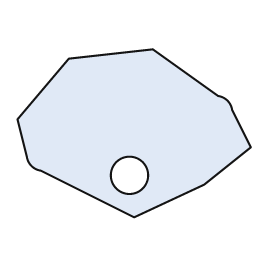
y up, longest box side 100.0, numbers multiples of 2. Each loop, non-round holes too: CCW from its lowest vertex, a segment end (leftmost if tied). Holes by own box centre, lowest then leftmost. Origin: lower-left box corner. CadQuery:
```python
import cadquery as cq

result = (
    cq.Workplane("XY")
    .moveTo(50.0, 0.0)
    .lineTo(80.0, 14.0)
    .lineTo(100.0, 30.0)
    .lineTo(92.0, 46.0)
    .threePointArc((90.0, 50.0), (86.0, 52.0))
    .lineTo(58.0, 72.0)
    .lineTo(22.0, 68.0)
    .lineTo(0.0, 42.0)
    .lineTo(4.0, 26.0)
    .threePointArc((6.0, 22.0), (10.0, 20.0))
    .close()
    .moveTo(48.0, 18.0)
    .circle(8.0)
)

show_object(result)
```